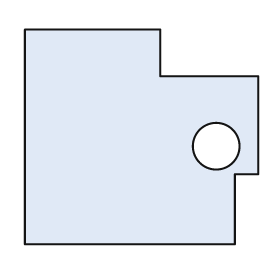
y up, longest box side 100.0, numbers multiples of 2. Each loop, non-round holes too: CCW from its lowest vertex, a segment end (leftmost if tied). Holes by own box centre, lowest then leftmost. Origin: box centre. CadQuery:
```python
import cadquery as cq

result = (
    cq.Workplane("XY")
    .moveTo(-50.0, -46.0)
    .lineTo(40.0, -46.0)
    .lineTo(40.0, -16.0)
    .lineTo(50.0, -16.0)
    .lineTo(50.0, 26.0)
    .lineTo(8.0, 26.0)
    .lineTo(8.0, 46.0)
    .lineTo(-50.0, 46.0)
    .close()
    .moveTo(32.0, -4.0)
    .circle(10.0)
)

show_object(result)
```